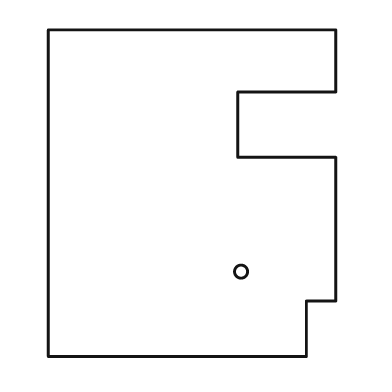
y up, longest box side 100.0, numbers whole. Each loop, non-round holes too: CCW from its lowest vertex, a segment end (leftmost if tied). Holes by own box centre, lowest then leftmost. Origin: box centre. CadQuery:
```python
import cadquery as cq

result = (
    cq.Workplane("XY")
    .moveTo(-44.0, -50.0)
    .lineTo(35.0, -50.0)
    .lineTo(35.0, -33.0)
    .lineTo(44.0, -33.0)
    .lineTo(44.0, 11.0)
    .lineTo(14.0, 11.0)
    .lineTo(14.0, 31.0)
    .lineTo(44.0, 31.0)
    .lineTo(44.0, 50.0)
    .lineTo(-44.0, 50.0)
    .close()
    .moveTo(15.0, -24.0)
    .circle(2.0)
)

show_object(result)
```